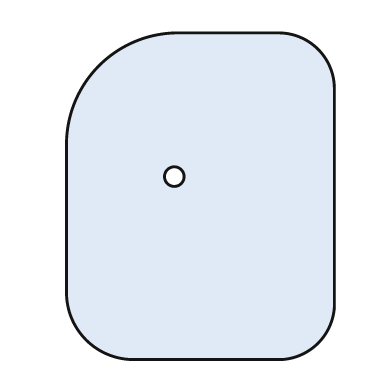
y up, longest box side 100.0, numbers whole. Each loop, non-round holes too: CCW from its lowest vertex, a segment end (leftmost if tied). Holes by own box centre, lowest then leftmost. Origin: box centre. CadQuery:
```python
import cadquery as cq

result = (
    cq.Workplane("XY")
    .moveTo(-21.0, -50.0)
    .lineTo(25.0, -50.0)
    .threePointArc((36.0, -45.0), (41.0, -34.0))
    .lineTo(41.0, 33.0)
    .threePointArc((36.0, 45.0), (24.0, 50.0))
    .lineTo(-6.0, 50.0)
    .threePointArc((-31.0, 40.0), (-41.0, 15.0))
    .lineTo(-41.0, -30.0)
    .threePointArc((-35.0, -44.0), (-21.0, -50.0))
    .close()
    .moveTo(-8.0, 6.0)
    .circle(3.0)
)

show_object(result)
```